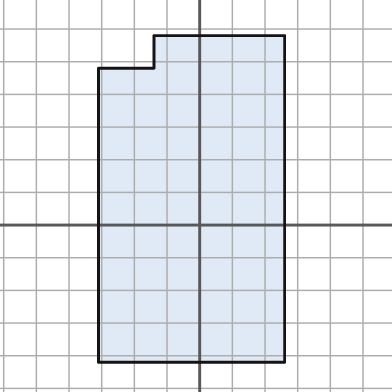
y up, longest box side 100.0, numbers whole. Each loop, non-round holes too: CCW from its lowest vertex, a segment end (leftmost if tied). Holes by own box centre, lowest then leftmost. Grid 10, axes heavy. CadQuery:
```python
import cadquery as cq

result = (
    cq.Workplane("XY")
    .moveTo(-31.0, -42.0)
    .lineTo(26.0, -42.0)
    .lineTo(26.0, 58.0)
    .lineTo(-14.0, 58.0)
    .lineTo(-14.0, 48.0)
    .lineTo(-31.0, 48.0)
    .close()
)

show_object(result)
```